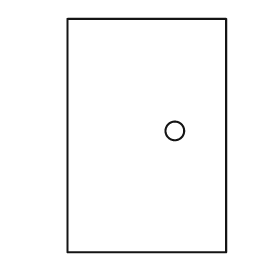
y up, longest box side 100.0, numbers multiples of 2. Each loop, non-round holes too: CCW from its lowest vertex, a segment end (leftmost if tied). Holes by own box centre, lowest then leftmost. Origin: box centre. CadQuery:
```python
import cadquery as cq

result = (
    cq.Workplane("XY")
    .moveTo(-34.0, -50.0)
    .lineTo(34.0, -50.0)
    .lineTo(34.0, 50.0)
    .lineTo(-34.0, 50.0)
    .close()
    .moveTo(12.0, 2.0)
    .circle(4.0)
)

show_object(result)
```